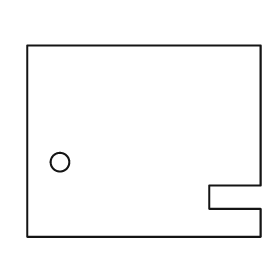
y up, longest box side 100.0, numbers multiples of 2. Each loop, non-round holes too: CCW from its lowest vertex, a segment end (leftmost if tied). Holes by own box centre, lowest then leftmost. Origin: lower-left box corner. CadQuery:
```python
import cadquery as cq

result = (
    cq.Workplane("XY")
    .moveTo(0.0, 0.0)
    .lineTo(100.0, 0.0)
    .lineTo(100.0, 12.0)
    .lineTo(78.0, 12.0)
    .lineTo(78.0, 22.0)
    .lineTo(100.0, 22.0)
    .lineTo(100.0, 82.0)
    .lineTo(0.0, 82.0)
    .close()
    .moveTo(14.0, 32.0)
    .circle(4.0)
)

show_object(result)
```